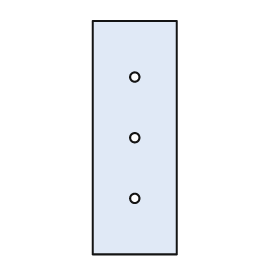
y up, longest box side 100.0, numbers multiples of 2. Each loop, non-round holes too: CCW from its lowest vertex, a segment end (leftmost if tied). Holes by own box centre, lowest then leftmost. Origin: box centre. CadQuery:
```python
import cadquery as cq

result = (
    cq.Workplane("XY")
    .moveTo(-18.0, -50.0)
    .lineTo(18.0, -50.0)
    .lineTo(18.0, 50.0)
    .lineTo(-18.0, 50.0)
    .close()
    .moveTo(0.0, -26.0)
    .circle(2.0)
    .moveTo(0.0, 0.0)
    .circle(2.0)
    .moveTo(0.0, 26.0)
    .circle(2.0)
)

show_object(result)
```